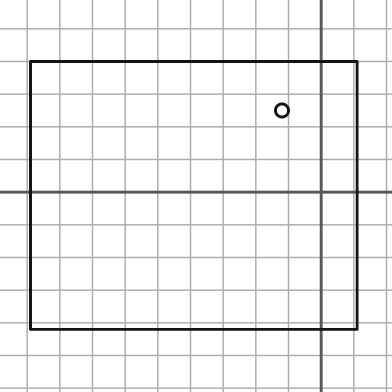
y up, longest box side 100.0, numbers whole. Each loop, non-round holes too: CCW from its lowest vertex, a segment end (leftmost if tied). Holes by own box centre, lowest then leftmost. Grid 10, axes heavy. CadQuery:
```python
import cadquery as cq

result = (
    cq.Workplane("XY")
    .moveTo(-89.0, -42.0)
    .lineTo(11.0, -42.0)
    .lineTo(11.0, 40.0)
    .lineTo(-89.0, 40.0)
    .close()
    .moveTo(-12.0, 25.0)
    .circle(2.0)
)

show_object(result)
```